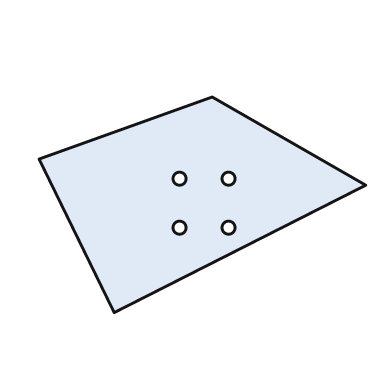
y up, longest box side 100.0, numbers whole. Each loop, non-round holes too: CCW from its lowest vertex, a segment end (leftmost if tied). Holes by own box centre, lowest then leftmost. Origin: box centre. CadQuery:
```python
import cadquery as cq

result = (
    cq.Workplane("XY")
    .moveTo(-27.0, -33.0)
    .lineTo(50.0, 6.0)
    .lineTo(3.0, 33.0)
    .lineTo(-50.0, 14.0)
    .close()
    .moveTo(-7.0, -7.0)
    .circle(2.0)
    .moveTo(8.0, -7.0)
    .circle(2.0)
    .moveTo(-7.0, 8.0)
    .circle(2.0)
    .moveTo(8.0, 8.0)
    .circle(2.0)
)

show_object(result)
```